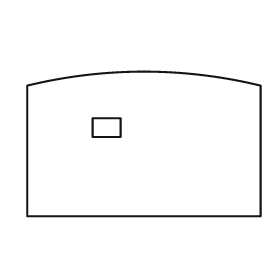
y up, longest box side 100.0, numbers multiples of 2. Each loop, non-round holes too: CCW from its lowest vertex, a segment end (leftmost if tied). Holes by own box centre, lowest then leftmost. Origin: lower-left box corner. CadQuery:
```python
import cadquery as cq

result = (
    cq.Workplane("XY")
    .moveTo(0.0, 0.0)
    .lineTo(100.0, 0.0)
    .lineTo(100.0, 56.0)
    .threePointArc((50.0, 62.0), (0.0, 56.0))
    .close()
    .moveTo(28.0, 34.0)
    .lineTo(40.0, 34.0)
    .lineTo(40.0, 42.0)
    .lineTo(28.0, 42.0)
    .close()
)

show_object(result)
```